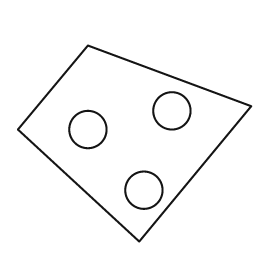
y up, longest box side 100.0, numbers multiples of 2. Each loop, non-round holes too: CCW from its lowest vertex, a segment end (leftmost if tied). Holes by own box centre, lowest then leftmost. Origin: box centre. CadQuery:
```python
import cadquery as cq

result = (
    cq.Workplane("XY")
    .moveTo(2.0, -42.0)
    .lineTo(50.0, 16.0)
    .lineTo(-20.0, 42.0)
    .lineTo(-50.0, 6.0)
    .close()
    .moveTo(4.0, -20.0)
    .circle(8.0)
    .moveTo(-20.0, 6.0)
    .circle(8.0)
    .moveTo(16.0, 14.0)
    .circle(8.0)
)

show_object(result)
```